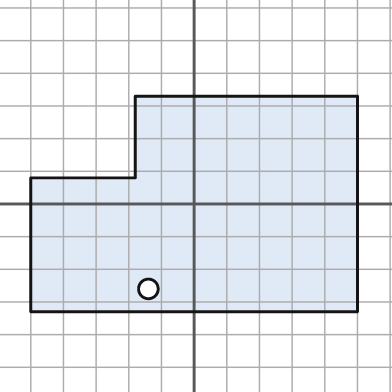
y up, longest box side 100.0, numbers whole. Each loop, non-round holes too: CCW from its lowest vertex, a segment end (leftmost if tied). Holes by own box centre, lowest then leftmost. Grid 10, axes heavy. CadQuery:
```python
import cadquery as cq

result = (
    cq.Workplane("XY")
    .moveTo(-50.0, -33.0)
    .lineTo(50.0, -33.0)
    .lineTo(50.0, 33.0)
    .lineTo(-18.0, 33.0)
    .lineTo(-18.0, 8.0)
    .lineTo(-50.0, 8.0)
    .close()
    .moveTo(-14.0, -26.0)
    .circle(3.0)
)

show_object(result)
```